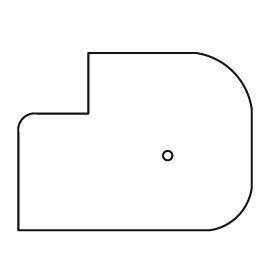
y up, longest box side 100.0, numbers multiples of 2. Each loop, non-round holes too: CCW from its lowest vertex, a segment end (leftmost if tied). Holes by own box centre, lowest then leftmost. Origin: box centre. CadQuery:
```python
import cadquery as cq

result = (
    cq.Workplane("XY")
    .moveTo(-50.0, -38.0)
    .lineTo(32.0, -38.0)
    .threePointArc((44.0, -32.0), (50.0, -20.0))
    .lineTo(50.0, 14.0)
    .threePointArc((42.0, 30.0), (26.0, 38.0))
    .lineTo(-20.0, 38.0)
    .lineTo(-20.0, 12.0)
    .lineTo(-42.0, 12.0)
    .threePointArc((-48.0, 10.0), (-50.0, 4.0))
    .close()
    .moveTo(14.0, -6.0)
    .circle(2.0)
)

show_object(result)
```